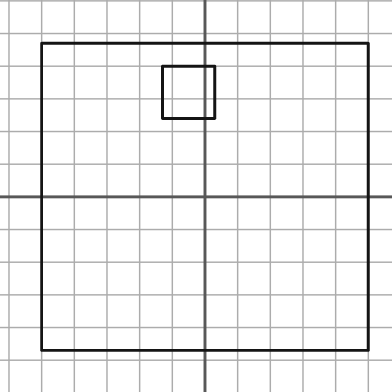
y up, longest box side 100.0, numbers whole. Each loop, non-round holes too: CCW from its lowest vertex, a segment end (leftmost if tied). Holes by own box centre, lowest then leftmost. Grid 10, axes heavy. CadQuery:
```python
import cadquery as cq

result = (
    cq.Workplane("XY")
    .moveTo(-50.0, -47.0)
    .lineTo(50.0, -47.0)
    .lineTo(50.0, 47.0)
    .lineTo(-50.0, 47.0)
    .close()
    .moveTo(-13.0, 24.0)
    .lineTo(3.0, 24.0)
    .lineTo(3.0, 40.0)
    .lineTo(-13.0, 40.0)
    .close()
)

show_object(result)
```